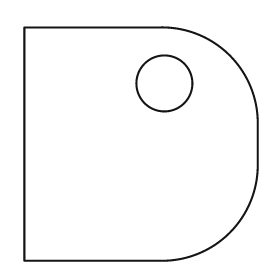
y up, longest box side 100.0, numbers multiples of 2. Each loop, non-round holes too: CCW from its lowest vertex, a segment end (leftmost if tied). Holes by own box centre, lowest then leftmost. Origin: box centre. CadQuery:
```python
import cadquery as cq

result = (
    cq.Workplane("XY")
    .moveTo(-50.0, -50.0)
    .lineTo(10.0, -50.0)
    .threePointArc((38.0, -38.0), (50.0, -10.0))
    .lineTo(50.0, 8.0)
    .threePointArc((38.0, 38.0), (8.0, 50.0))
    .lineTo(-50.0, 50.0)
    .close()
    .moveTo(10.0, 26.0)
    .circle(12.0)
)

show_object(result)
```